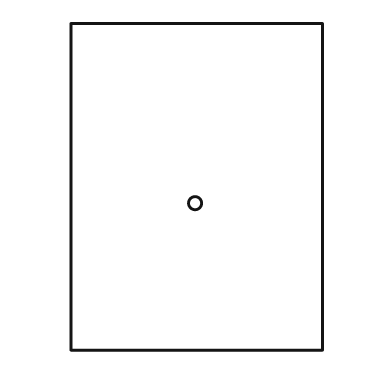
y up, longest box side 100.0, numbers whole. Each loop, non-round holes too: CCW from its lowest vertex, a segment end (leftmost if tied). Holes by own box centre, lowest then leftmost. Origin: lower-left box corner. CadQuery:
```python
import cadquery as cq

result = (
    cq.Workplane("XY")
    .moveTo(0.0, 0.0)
    .lineTo(77.0, 0.0)
    .lineTo(77.0, 100.0)
    .lineTo(0.0, 100.0)
    .close()
    .moveTo(38.0, 45.0)
    .circle(2.0)
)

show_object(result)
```